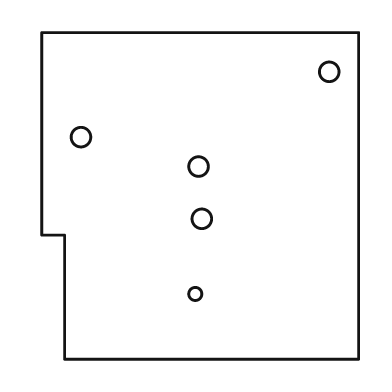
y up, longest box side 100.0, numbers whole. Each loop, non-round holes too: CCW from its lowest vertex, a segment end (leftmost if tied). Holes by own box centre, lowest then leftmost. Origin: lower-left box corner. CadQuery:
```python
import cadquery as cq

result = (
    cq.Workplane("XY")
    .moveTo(7.0, 0.0)
    .lineTo(97.0, 0.0)
    .lineTo(97.0, 100.0)
    .lineTo(0.0, 100.0)
    .lineTo(0.0, 38.0)
    .lineTo(7.0, 38.0)
    .close()
    .moveTo(47.0, 20.0)
    .circle(2.0)
    .moveTo(49.0, 43.0)
    .circle(3.0)
    .moveTo(48.0, 59.0)
    .circle(3.0)
    .moveTo(12.0, 68.0)
    .circle(3.0)
    .moveTo(88.0, 88.0)
    .circle(3.0)
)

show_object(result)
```